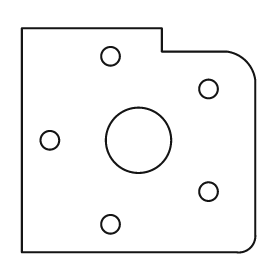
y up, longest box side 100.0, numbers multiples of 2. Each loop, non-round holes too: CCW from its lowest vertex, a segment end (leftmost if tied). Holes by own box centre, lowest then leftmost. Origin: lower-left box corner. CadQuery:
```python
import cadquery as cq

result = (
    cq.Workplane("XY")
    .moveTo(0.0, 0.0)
    .lineTo(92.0, 0.0)
    .threePointArc((98.0, 2.0), (100.0, 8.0))
    .lineTo(100.0, 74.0)
    .threePointArc((96.0, 82.0), (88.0, 86.0))
    .lineTo(60.0, 86.0)
    .lineTo(60.0, 96.0)
    .lineTo(0.0, 96.0)
    .close()
    .moveTo(38.0, 12.0)
    .circle(4.0)
    .moveTo(80.0, 26.0)
    .circle(4.0)
    .moveTo(12.0, 48.0)
    .circle(4.0)
    .moveTo(50.0, 48.0)
    .circle(14.0)
    .moveTo(80.0, 70.0)
    .circle(4.0)
    .moveTo(38.0, 84.0)
    .circle(4.0)
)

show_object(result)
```